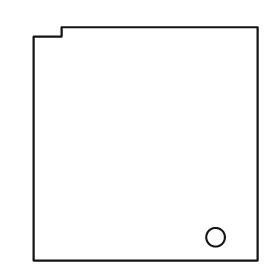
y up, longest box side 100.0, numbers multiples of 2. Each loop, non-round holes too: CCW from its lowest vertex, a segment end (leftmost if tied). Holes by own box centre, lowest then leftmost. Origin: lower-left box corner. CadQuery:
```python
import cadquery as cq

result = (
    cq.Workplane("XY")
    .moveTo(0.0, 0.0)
    .lineTo(96.0, 0.0)
    .lineTo(96.0, 100.0)
    .lineTo(12.0, 100.0)
    .lineTo(12.0, 96.0)
    .lineTo(0.0, 96.0)
    .close()
    .moveTo(78.0, 10.0)
    .circle(4.0)
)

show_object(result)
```